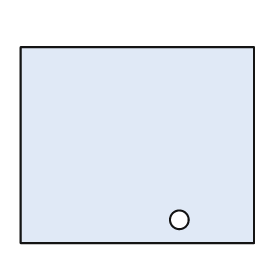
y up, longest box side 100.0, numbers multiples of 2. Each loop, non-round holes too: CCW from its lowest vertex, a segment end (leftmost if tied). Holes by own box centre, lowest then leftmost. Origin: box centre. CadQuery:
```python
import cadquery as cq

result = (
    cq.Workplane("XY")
    .moveTo(-50.0, -42.0)
    .lineTo(50.0, -42.0)
    .lineTo(50.0, 42.0)
    .lineTo(-50.0, 42.0)
    .close()
    .moveTo(18.0, -32.0)
    .circle(4.0)
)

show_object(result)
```